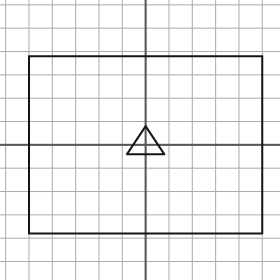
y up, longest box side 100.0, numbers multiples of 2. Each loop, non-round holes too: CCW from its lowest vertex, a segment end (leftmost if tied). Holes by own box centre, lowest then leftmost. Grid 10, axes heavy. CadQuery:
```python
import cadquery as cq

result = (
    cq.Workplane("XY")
    .moveTo(-50.0, -38.0)
    .lineTo(50.0, -38.0)
    .lineTo(50.0, 38.0)
    .lineTo(-50.0, 38.0)
    .close()
    .moveTo(-8.0, -4.0)
    .lineTo(8.0, -4.0)
    .lineTo(0.0, 8.0)
    .close()
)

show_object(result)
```